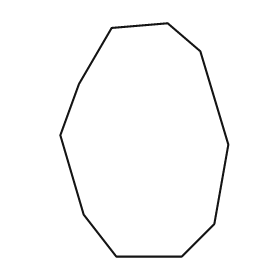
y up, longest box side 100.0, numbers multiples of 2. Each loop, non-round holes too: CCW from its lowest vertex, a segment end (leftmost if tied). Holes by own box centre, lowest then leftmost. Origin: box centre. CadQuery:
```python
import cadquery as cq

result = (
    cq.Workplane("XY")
    .moveTo(-12.0, -50.0)
    .lineTo(16.0, -50.0)
    .lineTo(30.0, -36.0)
    .lineTo(36.0, -2.0)
    .lineTo(24.0, 38.0)
    .lineTo(10.0, 50.0)
    .lineTo(-14.0, 48.0)
    .lineTo(-28.0, 24.0)
    .lineTo(-36.0, 2.0)
    .lineTo(-26.0, -32.0)
    .close()
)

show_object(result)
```